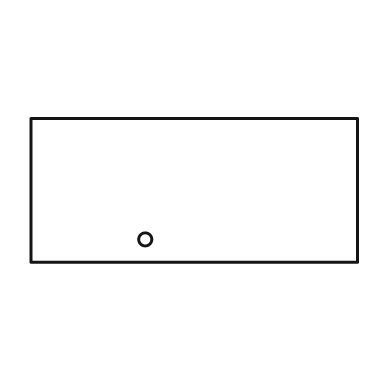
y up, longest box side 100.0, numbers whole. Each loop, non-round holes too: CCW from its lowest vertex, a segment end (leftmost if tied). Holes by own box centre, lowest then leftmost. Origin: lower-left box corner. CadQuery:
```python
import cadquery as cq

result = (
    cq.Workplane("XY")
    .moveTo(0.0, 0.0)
    .lineTo(100.0, 0.0)
    .lineTo(100.0, 44.0)
    .lineTo(0.0, 44.0)
    .close()
    .moveTo(35.0, 7.0)
    .circle(2.0)
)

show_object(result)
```